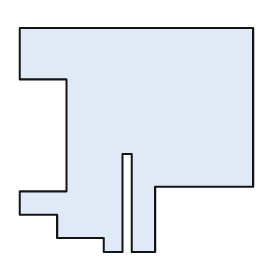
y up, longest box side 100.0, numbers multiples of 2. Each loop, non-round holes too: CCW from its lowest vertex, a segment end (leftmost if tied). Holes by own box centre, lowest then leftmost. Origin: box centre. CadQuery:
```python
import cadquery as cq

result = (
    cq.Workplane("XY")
    .moveTo(-14.0, -48.0)
    .lineTo(-6.0, -48.0)
    .lineTo(-6.0, -6.0)
    .lineTo(-2.0, -6.0)
    .lineTo(-2.0, -48.0)
    .lineTo(8.0, -48.0)
    .lineTo(8.0, -20.0)
    .lineTo(50.0, -20.0)
    .lineTo(50.0, 48.0)
    .lineTo(-50.0, 48.0)
    .lineTo(-50.0, 26.0)
    .lineTo(-30.0, 26.0)
    .lineTo(-30.0, -22.0)
    .lineTo(-50.0, -22.0)
    .lineTo(-50.0, -32.0)
    .lineTo(-34.0, -32.0)
    .lineTo(-34.0, -42.0)
    .lineTo(-14.0, -42.0)
    .close()
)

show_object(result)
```